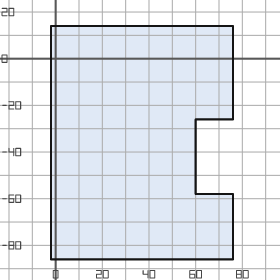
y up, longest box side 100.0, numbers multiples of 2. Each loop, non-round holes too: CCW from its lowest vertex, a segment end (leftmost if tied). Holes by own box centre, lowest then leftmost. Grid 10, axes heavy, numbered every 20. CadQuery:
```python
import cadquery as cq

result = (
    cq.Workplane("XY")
    .moveTo(-2.0, -86.0)
    .lineTo(76.0, -86.0)
    .lineTo(76.0, -58.0)
    .lineTo(60.0, -58.0)
    .lineTo(60.0, -26.0)
    .lineTo(76.0, -26.0)
    .lineTo(76.0, 14.0)
    .lineTo(-2.0, 14.0)
    .close()
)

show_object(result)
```